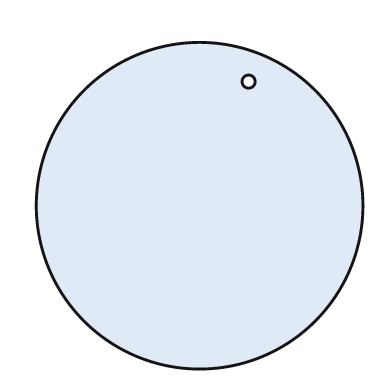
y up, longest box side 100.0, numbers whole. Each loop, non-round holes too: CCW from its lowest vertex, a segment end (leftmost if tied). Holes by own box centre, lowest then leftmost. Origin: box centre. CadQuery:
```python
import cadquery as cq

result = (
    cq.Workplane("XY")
    .moveTo(0.0, 0.0)
    .circle(50.0)
    .moveTo(15.0, 38.0)
    .circle(2.0)
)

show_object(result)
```